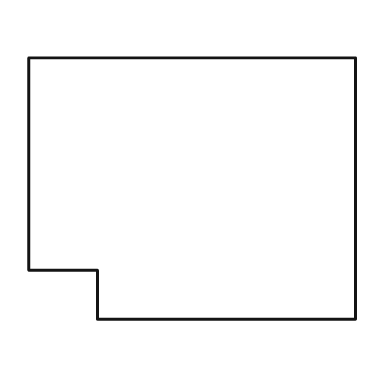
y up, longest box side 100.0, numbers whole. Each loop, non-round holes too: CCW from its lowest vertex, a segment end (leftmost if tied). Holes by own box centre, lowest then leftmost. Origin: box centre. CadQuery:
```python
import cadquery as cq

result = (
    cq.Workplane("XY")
    .moveTo(-29.0, -40.0)
    .lineTo(50.0, -40.0)
    .lineTo(50.0, 40.0)
    .lineTo(-50.0, 40.0)
    .lineTo(-50.0, -25.0)
    .lineTo(-29.0, -25.0)
    .close()
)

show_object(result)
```